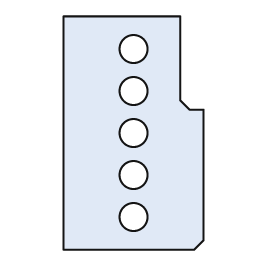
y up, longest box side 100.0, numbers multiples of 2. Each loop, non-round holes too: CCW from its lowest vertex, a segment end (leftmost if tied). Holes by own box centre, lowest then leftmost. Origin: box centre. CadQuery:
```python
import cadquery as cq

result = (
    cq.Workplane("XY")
    .moveTo(-30.0, -50.0)
    .lineTo(26.0, -50.0)
    .lineTo(30.0, -46.0)
    .lineTo(30.0, 10.0)
    .lineTo(24.0, 10.0)
    .lineTo(20.0, 14.0)
    .lineTo(20.0, 50.0)
    .lineTo(-30.0, 50.0)
    .close()
    .moveTo(0.0, -36.0)
    .circle(6.0)
    .moveTo(0.0, -18.0)
    .circle(6.0)
    .moveTo(0.0, 0.0)
    .circle(6.0)
    .moveTo(0.0, 18.0)
    .circle(6.0)
    .moveTo(0.0, 36.0)
    .circle(6.0)
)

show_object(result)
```